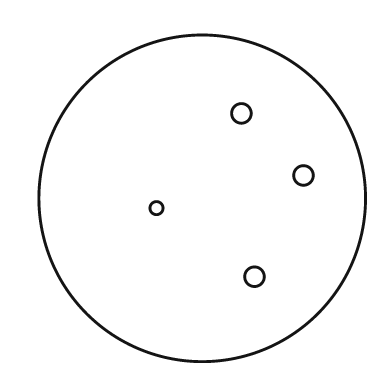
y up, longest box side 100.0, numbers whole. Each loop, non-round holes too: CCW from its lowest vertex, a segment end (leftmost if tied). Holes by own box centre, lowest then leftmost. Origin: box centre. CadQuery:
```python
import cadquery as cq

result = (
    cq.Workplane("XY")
    .moveTo(0.0, 0.0)
    .circle(50.0)
    .moveTo(16.0, -24.0)
    .circle(3.0)
    .moveTo(-14.0, -3.0)
    .circle(2.0)
    .moveTo(31.0, 7.0)
    .circle(3.0)
    .moveTo(12.0, 26.0)
    .circle(3.0)
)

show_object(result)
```